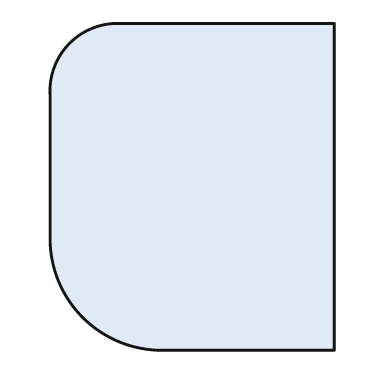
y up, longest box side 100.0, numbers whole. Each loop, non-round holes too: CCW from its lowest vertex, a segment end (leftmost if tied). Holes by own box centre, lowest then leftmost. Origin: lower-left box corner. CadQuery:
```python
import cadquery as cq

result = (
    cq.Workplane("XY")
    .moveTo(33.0, 0.0)
    .lineTo(87.0, 0.0)
    .lineTo(87.0, 100.0)
    .lineTo(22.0, 100.0)
    .threePointArc((6.0, 94.0), (0.0, 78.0))
    .lineTo(0.0, 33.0)
    .threePointArc((10.0, 10.0), (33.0, 0.0))
    .close()
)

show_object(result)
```